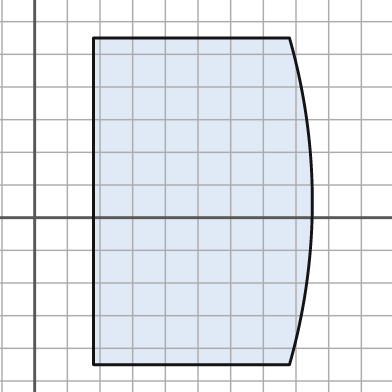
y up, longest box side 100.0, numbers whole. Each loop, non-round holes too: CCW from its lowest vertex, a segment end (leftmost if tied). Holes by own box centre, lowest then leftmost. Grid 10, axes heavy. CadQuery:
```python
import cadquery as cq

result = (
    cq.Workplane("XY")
    .moveTo(18.0, -45.0)
    .lineTo(78.0, -45.0)
    .threePointArc((85.0, 5.0), (78.0, 55.0))
    .lineTo(18.0, 55.0)
    .close()
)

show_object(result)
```